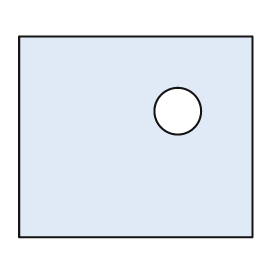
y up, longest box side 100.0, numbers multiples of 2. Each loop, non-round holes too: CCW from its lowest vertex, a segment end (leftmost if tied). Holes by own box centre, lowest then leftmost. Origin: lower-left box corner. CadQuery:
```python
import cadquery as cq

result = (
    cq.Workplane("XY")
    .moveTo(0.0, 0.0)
    .lineTo(100.0, 0.0)
    .lineTo(100.0, 86.0)
    .lineTo(0.0, 86.0)
    .close()
    .moveTo(68.0, 54.0)
    .circle(10.0)
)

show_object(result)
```